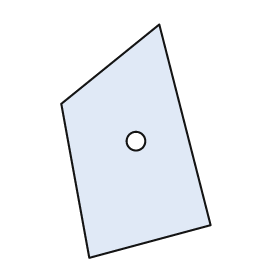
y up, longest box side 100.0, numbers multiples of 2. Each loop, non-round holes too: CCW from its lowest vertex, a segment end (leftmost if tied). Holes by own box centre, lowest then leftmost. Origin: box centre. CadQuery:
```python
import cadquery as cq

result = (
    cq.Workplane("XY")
    .moveTo(-20.0, -50.0)
    .lineTo(32.0, -36.0)
    .lineTo(10.0, 50.0)
    .lineTo(-32.0, 16.0)
    .close()
    .moveTo(0.0, 0.0)
    .circle(4.0)
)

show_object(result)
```